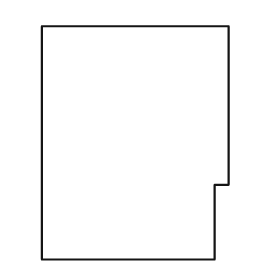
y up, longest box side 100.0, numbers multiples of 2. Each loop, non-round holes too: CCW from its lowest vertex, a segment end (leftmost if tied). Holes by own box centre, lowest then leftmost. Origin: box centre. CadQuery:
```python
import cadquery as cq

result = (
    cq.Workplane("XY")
    .moveTo(-40.0, -50.0)
    .lineTo(34.0, -50.0)
    .lineTo(34.0, -18.0)
    .lineTo(40.0, -18.0)
    .lineTo(40.0, 50.0)
    .lineTo(-40.0, 50.0)
    .close()
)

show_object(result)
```